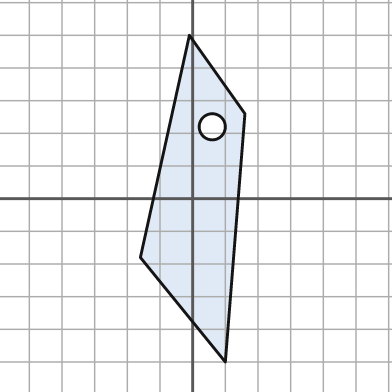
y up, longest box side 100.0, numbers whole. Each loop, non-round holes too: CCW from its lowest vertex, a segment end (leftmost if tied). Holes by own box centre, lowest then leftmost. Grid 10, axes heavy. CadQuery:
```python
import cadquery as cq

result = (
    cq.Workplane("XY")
    .moveTo(10.0, -50.0)
    .lineTo(16.0, 26.0)
    .lineTo(-1.0, 50.0)
    .lineTo(-16.0, -18.0)
    .close()
    .moveTo(6.0, 22.0)
    .circle(4.0)
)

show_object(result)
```